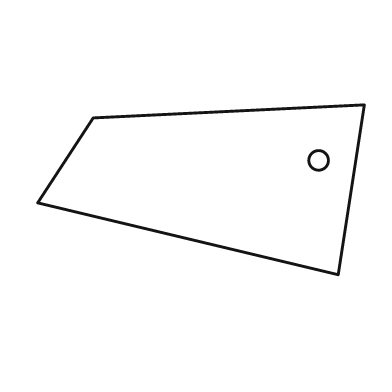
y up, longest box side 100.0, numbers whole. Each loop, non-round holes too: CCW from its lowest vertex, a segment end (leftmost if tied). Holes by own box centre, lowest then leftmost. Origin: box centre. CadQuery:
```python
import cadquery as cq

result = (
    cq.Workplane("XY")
    .moveTo(42.0, -26.0)
    .lineTo(50.0, 26.0)
    .lineTo(-33.0, 22.0)
    .lineTo(-50.0, -4.0)
    .close()
    .moveTo(36.0, 9.0)
    .circle(3.0)
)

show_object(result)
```